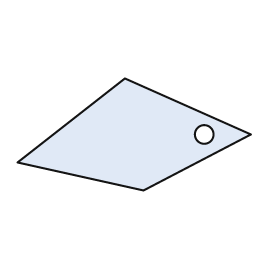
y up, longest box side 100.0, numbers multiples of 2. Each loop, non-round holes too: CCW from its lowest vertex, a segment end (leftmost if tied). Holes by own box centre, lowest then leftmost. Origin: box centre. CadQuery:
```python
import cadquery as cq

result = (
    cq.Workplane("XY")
    .moveTo(4.0, -24.0)
    .lineTo(50.0, 0.0)
    .lineTo(-4.0, 24.0)
    .lineTo(-50.0, -12.0)
    .close()
    .moveTo(30.0, 0.0)
    .circle(4.0)
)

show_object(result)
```